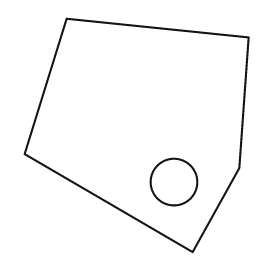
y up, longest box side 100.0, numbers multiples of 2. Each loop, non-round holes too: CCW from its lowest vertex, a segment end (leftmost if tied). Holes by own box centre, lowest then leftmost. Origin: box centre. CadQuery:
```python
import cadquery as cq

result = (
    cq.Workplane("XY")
    .moveTo(24.0, -50.0)
    .lineTo(44.0, -14.0)
    .lineTo(48.0, 42.0)
    .lineTo(-30.0, 50.0)
    .lineTo(-48.0, -8.0)
    .close()
    .moveTo(16.0, -20.0)
    .circle(10.0)
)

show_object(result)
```